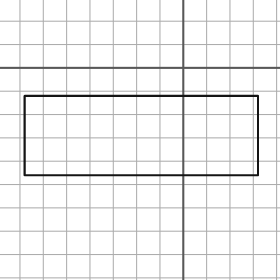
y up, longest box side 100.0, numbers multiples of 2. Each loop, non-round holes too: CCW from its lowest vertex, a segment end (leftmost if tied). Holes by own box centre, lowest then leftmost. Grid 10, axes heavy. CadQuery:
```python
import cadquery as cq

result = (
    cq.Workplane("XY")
    .moveTo(-68.0, -46.0)
    .lineTo(32.0, -46.0)
    .lineTo(32.0, -12.0)
    .lineTo(-68.0, -12.0)
    .close()
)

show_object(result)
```